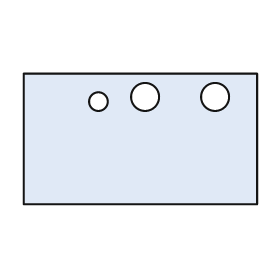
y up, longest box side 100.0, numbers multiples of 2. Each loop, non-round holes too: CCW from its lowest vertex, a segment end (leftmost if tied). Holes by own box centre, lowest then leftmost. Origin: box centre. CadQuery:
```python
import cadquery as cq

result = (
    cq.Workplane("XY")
    .moveTo(-50.0, -28.0)
    .lineTo(50.0, -28.0)
    .lineTo(50.0, 28.0)
    .lineTo(-50.0, 28.0)
    .close()
    .moveTo(-18.0, 16.0)
    .circle(4.0)
    .moveTo(2.0, 18.0)
    .circle(6.0)
    .moveTo(32.0, 18.0)
    .circle(6.0)
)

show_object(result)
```